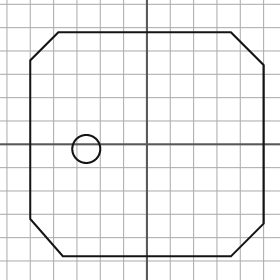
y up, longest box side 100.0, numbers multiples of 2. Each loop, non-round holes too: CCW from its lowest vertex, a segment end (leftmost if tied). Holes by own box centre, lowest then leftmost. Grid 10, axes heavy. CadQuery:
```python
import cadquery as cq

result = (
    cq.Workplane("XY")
    .moveTo(-36.0, -48.0)
    .lineTo(36.0, -48.0)
    .lineTo(50.0, -34.0)
    .lineTo(50.0, 34.0)
    .lineTo(36.0, 48.0)
    .lineTo(-38.0, 48.0)
    .lineTo(-50.0, 36.0)
    .lineTo(-50.0, -32.0)
    .close()
    .moveTo(-26.0, -2.0)
    .circle(6.0)
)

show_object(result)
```